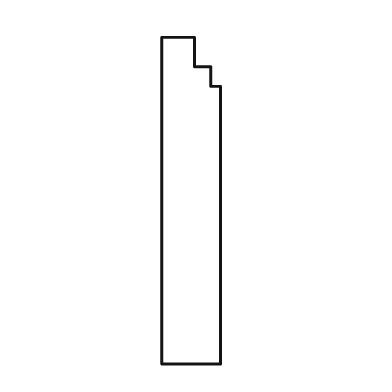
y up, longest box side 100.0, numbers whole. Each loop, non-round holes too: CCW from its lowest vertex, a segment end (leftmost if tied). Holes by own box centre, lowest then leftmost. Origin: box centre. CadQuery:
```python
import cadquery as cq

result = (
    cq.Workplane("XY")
    .moveTo(-9.0, -50.0)
    .lineTo(9.0, -50.0)
    .lineTo(9.0, 35.0)
    .lineTo(6.0, 35.0)
    .lineTo(6.0, 41.0)
    .lineTo(1.0, 41.0)
    .lineTo(1.0, 50.0)
    .lineTo(-9.0, 50.0)
    .close()
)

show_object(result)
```